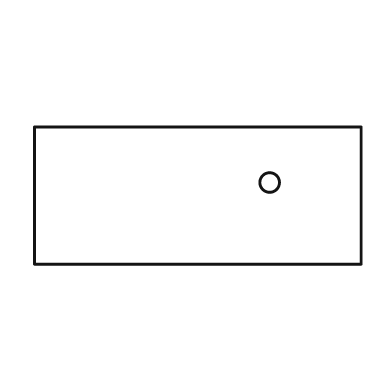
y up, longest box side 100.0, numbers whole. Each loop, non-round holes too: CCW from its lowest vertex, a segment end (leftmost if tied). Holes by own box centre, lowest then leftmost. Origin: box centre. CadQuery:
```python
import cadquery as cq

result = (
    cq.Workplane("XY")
    .moveTo(-50.0, -21.0)
    .lineTo(50.0, -21.0)
    .lineTo(50.0, 21.0)
    .lineTo(-50.0, 21.0)
    .close()
    .moveTo(22.0, 4.0)
    .circle(3.0)
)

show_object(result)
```